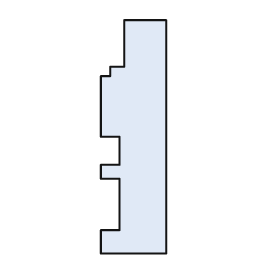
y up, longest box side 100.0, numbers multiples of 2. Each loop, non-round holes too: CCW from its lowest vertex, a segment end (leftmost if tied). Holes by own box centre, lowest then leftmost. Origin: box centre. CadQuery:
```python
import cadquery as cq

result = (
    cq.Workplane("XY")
    .moveTo(-14.0, -50.0)
    .lineTo(14.0, -50.0)
    .lineTo(14.0, 50.0)
    .lineTo(-4.0, 50.0)
    .lineTo(-4.0, 30.0)
    .lineTo(-10.0, 30.0)
    .lineTo(-10.0, 26.0)
    .lineTo(-14.0, 26.0)
    .lineTo(-14.0, 0.0)
    .lineTo(-6.0, 0.0)
    .lineTo(-6.0, -12.0)
    .lineTo(-14.0, -12.0)
    .lineTo(-14.0, -18.0)
    .lineTo(-6.0, -18.0)
    .lineTo(-6.0, -40.0)
    .lineTo(-14.0, -40.0)
    .close()
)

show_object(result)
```